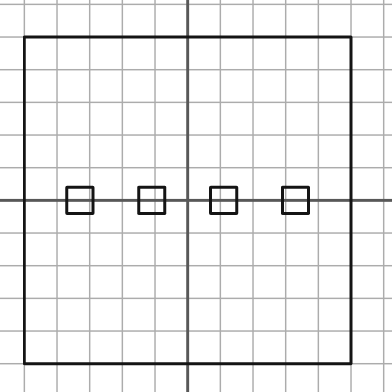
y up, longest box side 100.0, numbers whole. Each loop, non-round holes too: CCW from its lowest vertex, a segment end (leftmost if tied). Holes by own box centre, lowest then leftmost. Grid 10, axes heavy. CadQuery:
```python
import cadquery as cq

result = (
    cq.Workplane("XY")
    .moveTo(-50.0, -50.0)
    .lineTo(50.0, -50.0)
    .lineTo(50.0, 50.0)
    .lineTo(-50.0, 50.0)
    .close()
    .moveTo(-37.0, -4.0)
    .lineTo(-29.0, -4.0)
    .lineTo(-29.0, 4.0)
    .lineTo(-37.0, 4.0)
    .close()
    .moveTo(-15.0, -4.0)
    .lineTo(-7.0, -4.0)
    .lineTo(-7.0, 4.0)
    .lineTo(-15.0, 4.0)
    .close()
    .moveTo(7.0, -4.0)
    .lineTo(15.0, -4.0)
    .lineTo(15.0, 4.0)
    .lineTo(7.0, 4.0)
    .close()
    .moveTo(29.0, -4.0)
    .lineTo(37.0, -4.0)
    .lineTo(37.0, 4.0)
    .lineTo(29.0, 4.0)
    .close()
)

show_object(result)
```